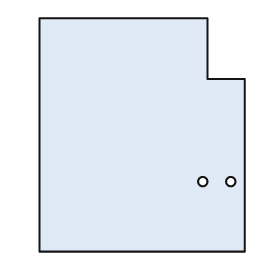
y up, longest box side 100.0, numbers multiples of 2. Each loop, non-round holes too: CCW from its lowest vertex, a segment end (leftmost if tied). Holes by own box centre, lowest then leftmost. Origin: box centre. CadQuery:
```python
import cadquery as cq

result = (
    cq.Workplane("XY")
    .moveTo(-44.0, -50.0)
    .lineTo(44.0, -50.0)
    .lineTo(44.0, 24.0)
    .lineTo(28.0, 24.0)
    .lineTo(28.0, 50.0)
    .lineTo(-44.0, 50.0)
    .close()
    .moveTo(26.0, -20.0)
    .circle(2.0)
    .moveTo(38.0, -20.0)
    .circle(2.0)
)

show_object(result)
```